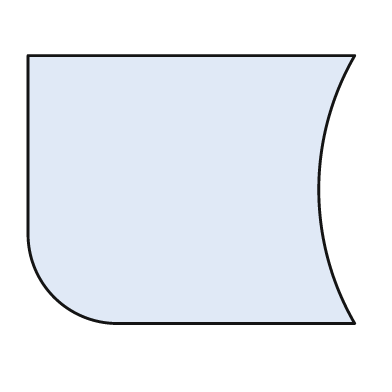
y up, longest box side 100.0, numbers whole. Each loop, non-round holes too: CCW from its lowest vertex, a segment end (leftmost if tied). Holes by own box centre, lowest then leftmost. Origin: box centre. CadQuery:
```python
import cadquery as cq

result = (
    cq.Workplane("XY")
    .moveTo(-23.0, -41.0)
    .lineTo(50.0, -41.0)
    .threePointArc((39.0, 0.0), (50.0, 41.0))
    .lineTo(-50.0, 41.0)
    .lineTo(-50.0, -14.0)
    .threePointArc((-42.0, -33.0), (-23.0, -41.0))
    .close()
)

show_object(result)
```